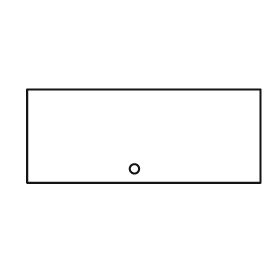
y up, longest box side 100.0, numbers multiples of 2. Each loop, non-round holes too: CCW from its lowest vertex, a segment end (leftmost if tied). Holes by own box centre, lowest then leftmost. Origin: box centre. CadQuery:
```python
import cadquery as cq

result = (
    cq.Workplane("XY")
    .moveTo(-50.0, -20.0)
    .lineTo(50.0, -20.0)
    .lineTo(50.0, 20.0)
    .lineTo(-50.0, 20.0)
    .close()
    .moveTo(-4.0, -14.0)
    .circle(2.0)
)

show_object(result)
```